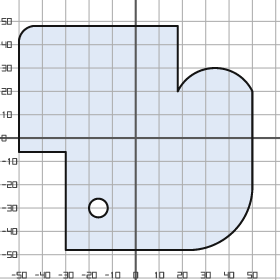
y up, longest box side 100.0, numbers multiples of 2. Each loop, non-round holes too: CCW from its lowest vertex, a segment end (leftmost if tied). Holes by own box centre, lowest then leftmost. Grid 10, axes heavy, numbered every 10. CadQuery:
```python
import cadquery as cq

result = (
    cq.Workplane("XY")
    .moveTo(-30.0, -48.0)
    .lineTo(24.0, -48.0)
    .threePointArc((42.0, -40.0), (50.0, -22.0))
    .lineTo(50.0, 20.0)
    .threePointArc((34.0, 30.0), (18.0, 20.0))
    .lineTo(18.0, 48.0)
    .lineTo(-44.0, 48.0)
    .threePointArc((-48.0, 46.0), (-50.0, 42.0))
    .lineTo(-50.0, -6.0)
    .lineTo(-30.0, -6.0)
    .close()
    .moveTo(-16.0, -30.0)
    .circle(4.0)
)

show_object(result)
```